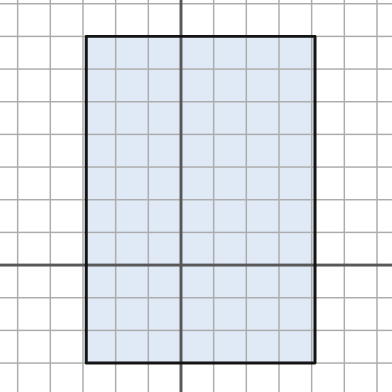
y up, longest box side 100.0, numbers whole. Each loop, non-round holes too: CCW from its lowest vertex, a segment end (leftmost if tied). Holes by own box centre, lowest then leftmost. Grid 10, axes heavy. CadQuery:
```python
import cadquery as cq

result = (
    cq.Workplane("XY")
    .moveTo(-29.0, -30.0)
    .lineTo(41.0, -30.0)
    .lineTo(41.0, 70.0)
    .lineTo(-29.0, 70.0)
    .close()
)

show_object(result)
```